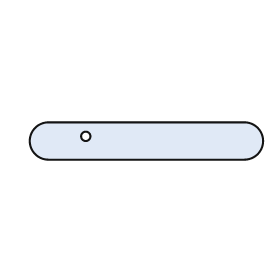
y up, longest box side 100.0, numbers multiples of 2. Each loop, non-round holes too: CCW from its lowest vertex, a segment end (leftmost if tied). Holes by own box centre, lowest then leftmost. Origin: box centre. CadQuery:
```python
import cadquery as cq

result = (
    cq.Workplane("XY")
    .moveTo(-42.0, -8.0)
    .lineTo(42.0, -8.0)
    .threePointArc((50.0, 0.0), (42.0, 8.0))
    .lineTo(-42.0, 8.0)
    .threePointArc((-50.0, 0.0), (-42.0, -8.0))
    .close()
    .moveTo(-26.0, 2.0)
    .circle(2.0)
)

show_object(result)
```